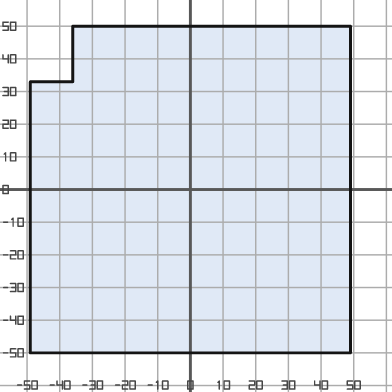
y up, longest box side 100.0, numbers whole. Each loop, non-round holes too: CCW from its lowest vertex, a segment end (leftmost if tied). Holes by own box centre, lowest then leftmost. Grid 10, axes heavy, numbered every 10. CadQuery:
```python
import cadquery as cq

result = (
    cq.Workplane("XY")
    .moveTo(-49.0, -50.0)
    .lineTo(49.0, -50.0)
    .lineTo(49.0, 50.0)
    .lineTo(-36.0, 50.0)
    .lineTo(-36.0, 33.0)
    .lineTo(-49.0, 33.0)
    .close()
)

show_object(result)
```